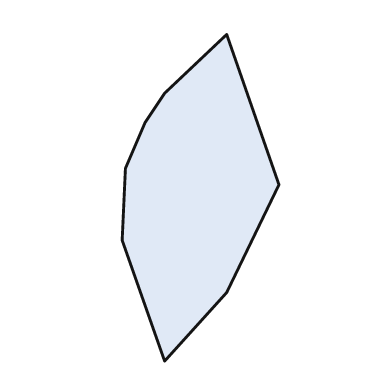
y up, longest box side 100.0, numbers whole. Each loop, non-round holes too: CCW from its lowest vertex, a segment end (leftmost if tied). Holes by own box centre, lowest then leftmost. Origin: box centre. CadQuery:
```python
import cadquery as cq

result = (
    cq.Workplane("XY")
    .moveTo(-11.0, -50.0)
    .lineTo(8.0, -29.0)
    .lineTo(24.0, 4.0)
    .lineTo(8.0, 50.0)
    .lineTo(-11.0, 32.0)
    .lineTo(-17.0, 23.0)
    .lineTo(-23.0, 9.0)
    .lineTo(-24.0, -13.0)
    .close()
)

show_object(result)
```